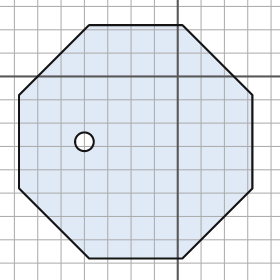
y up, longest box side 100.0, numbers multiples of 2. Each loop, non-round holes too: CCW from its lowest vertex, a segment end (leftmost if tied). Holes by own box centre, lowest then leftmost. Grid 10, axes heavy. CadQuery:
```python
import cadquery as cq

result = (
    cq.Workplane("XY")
    .moveTo(-38.0, -78.0)
    .lineTo(2.0, -78.0)
    .lineTo(32.0, -48.0)
    .lineTo(32.0, -8.0)
    .lineTo(2.0, 22.0)
    .lineTo(-38.0, 22.0)
    .lineTo(-68.0, -8.0)
    .lineTo(-68.0, -48.0)
    .close()
    .moveTo(-40.0, -28.0)
    .circle(4.0)
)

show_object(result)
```